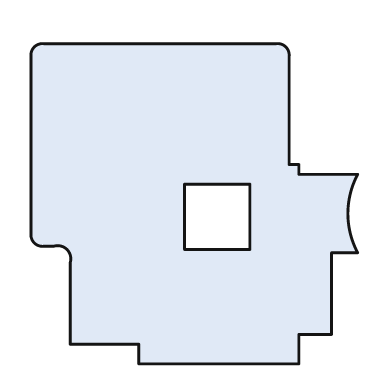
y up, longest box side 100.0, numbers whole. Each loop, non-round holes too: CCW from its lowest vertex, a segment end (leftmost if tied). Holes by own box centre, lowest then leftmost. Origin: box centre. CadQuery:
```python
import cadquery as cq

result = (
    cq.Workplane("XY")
    .moveTo(-17.0, -49.0)
    .lineTo(32.0, -49.0)
    .lineTo(32.0, -40.0)
    .lineTo(42.0, -40.0)
    .lineTo(42.0, -15.0)
    .lineTo(50.0, -15.0)
    .threePointArc((47.0, -3.0), (50.0, 9.0))
    .lineTo(32.0, 9.0)
    .lineTo(32.0, 12.0)
    .lineTo(29.0, 12.0)
    .lineTo(29.0, 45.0)
    .threePointArc((28.0, 48.0), (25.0, 49.0))
    .lineTo(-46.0, 49.0)
    .threePointArc((-49.0, 48.0), (-50.0, 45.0))
    .lineTo(-50.0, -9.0)
    .threePointArc((-49.0, -12.0), (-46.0, -13.0))
    .lineTo(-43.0, -13.0)
    .threePointArc((-39.0, -14.0), (-38.0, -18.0))
    .lineTo(-38.0, -43.0)
    .lineTo(-17.0, -43.0)
    .close()
    .moveTo(-3.0, -14.0)
    .lineTo(17.0, -14.0)
    .lineTo(17.0, 6.0)
    .lineTo(-3.0, 6.0)
    .close()
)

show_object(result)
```